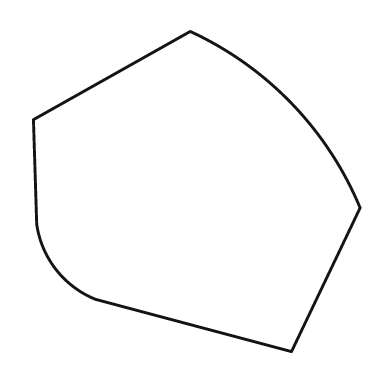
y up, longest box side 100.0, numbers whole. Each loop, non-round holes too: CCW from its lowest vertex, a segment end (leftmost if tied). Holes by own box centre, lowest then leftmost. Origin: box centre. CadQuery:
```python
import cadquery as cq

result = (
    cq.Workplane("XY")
    .moveTo(29.0, -49.0)
    .lineTo(50.0, -5.0)
    .threePointArc((29.0, 27.0), (-2.0, 49.0))
    .lineTo(-50.0, 22.0)
    .lineTo(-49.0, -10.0)
    .threePointArc((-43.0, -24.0), (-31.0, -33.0))
    .close()
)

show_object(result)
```